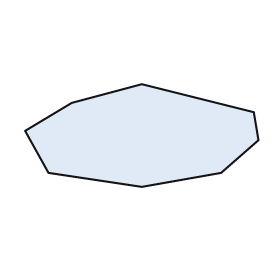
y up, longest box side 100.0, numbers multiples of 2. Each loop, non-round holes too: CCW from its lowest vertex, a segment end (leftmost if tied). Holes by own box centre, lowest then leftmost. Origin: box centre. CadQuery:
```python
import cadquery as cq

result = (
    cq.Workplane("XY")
    .moveTo(0.0, -22.0)
    .lineTo(34.0, -16.0)
    .lineTo(50.0, -2.0)
    .lineTo(48.0, 10.0)
    .lineTo(0.0, 22.0)
    .lineTo(-30.0, 14.0)
    .lineTo(-50.0, 2.0)
    .lineTo(-40.0, -16.0)
    .close()
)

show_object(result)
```